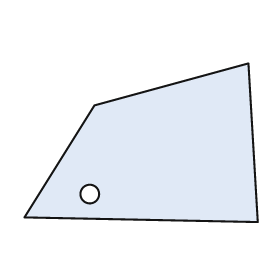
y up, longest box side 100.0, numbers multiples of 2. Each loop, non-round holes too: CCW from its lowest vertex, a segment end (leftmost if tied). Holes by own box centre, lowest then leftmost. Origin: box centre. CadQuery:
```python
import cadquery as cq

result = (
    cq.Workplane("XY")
    .moveTo(50.0, -34.0)
    .lineTo(46.0, 34.0)
    .lineTo(-20.0, 16.0)
    .lineTo(-50.0, -32.0)
    .close()
    .moveTo(-22.0, -22.0)
    .circle(4.0)
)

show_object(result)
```